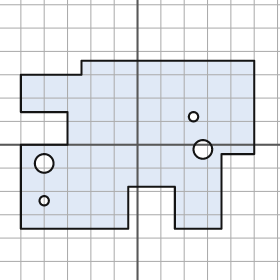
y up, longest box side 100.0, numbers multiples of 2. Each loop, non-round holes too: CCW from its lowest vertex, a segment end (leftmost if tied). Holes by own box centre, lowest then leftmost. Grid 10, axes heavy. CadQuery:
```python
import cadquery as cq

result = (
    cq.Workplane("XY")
    .moveTo(-50.0, -36.0)
    .lineTo(-4.0, -36.0)
    .lineTo(-4.0, -18.0)
    .lineTo(16.0, -18.0)
    .lineTo(16.0, -36.0)
    .lineTo(36.0, -36.0)
    .lineTo(36.0, -4.0)
    .lineTo(50.0, -4.0)
    .lineTo(50.0, 36.0)
    .lineTo(-24.0, 36.0)
    .lineTo(-24.0, 30.0)
    .lineTo(-50.0, 30.0)
    .lineTo(-50.0, 14.0)
    .lineTo(-30.0, 14.0)
    .lineTo(-30.0, 0.0)
    .lineTo(-50.0, 0.0)
    .close()
    .moveTo(-40.0, -24.0)
    .circle(2.0)
    .moveTo(-40.0, -8.0)
    .circle(4.0)
    .moveTo(28.0, -2.0)
    .circle(4.0)
    .moveTo(24.0, 12.0)
    .circle(2.0)
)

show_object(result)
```